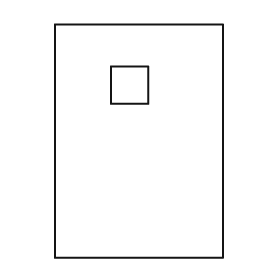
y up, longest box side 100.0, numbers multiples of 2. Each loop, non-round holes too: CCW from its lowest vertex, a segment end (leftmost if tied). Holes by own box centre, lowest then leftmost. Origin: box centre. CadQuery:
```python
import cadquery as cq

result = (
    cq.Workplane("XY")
    .moveTo(-36.0, -50.0)
    .lineTo(36.0, -50.0)
    .lineTo(36.0, 50.0)
    .lineTo(-36.0, 50.0)
    .close()
    .moveTo(-12.0, 16.0)
    .lineTo(4.0, 16.0)
    .lineTo(4.0, 32.0)
    .lineTo(-12.0, 32.0)
    .close()
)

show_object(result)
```